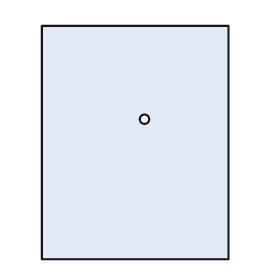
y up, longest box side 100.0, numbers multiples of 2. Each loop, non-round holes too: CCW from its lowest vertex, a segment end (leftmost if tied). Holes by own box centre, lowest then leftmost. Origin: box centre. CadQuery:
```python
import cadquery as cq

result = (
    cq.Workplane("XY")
    .moveTo(-40.0, -50.0)
    .lineTo(40.0, -50.0)
    .lineTo(40.0, 50.0)
    .lineTo(-40.0, 50.0)
    .close()
    .moveTo(4.0, 10.0)
    .circle(2.0)
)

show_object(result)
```